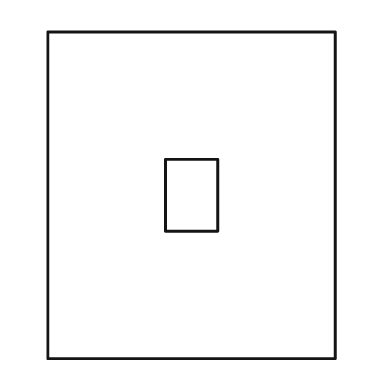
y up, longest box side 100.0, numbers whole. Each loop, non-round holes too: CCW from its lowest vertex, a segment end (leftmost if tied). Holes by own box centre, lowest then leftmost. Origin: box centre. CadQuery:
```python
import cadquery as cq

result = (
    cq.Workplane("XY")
    .moveTo(-44.0, -50.0)
    .lineTo(44.0, -50.0)
    .lineTo(44.0, 50.0)
    .lineTo(-44.0, 50.0)
    .close()
    .moveTo(-8.0, -11.0)
    .lineTo(8.0, -11.0)
    .lineTo(8.0, 11.0)
    .lineTo(-8.0, 11.0)
    .close()
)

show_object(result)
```